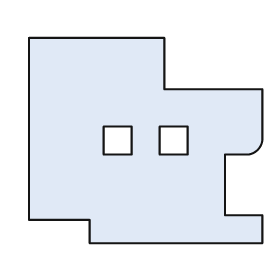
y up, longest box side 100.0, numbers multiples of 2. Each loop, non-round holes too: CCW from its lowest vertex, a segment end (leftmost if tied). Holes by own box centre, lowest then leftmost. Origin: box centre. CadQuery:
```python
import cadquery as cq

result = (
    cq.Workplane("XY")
    .moveTo(-24.0, -44.0)
    .lineTo(50.0, -44.0)
    .lineTo(50.0, -32.0)
    .lineTo(34.0, -32.0)
    .lineTo(34.0, -6.0)
    .lineTo(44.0, -6.0)
    .threePointArc((48.0, -4.0), (50.0, 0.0))
    .lineTo(50.0, 22.0)
    .lineTo(8.0, 22.0)
    .lineTo(8.0, 44.0)
    .lineTo(-50.0, 44.0)
    .lineTo(-50.0, -34.0)
    .lineTo(-24.0, -34.0)
    .close()
    .moveTo(-18.0, -6.0)
    .lineTo(-6.0, -6.0)
    .lineTo(-6.0, 6.0)
    .lineTo(-18.0, 6.0)
    .close()
    .moveTo(6.0, -6.0)
    .lineTo(18.0, -6.0)
    .lineTo(18.0, 6.0)
    .lineTo(6.0, 6.0)
    .close()
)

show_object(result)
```